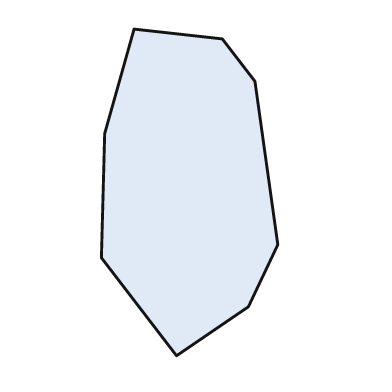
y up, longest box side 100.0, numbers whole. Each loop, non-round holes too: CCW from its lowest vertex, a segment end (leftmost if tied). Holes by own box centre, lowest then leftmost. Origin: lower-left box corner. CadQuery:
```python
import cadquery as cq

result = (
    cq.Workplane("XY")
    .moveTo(23.0, 0.0)
    .lineTo(45.0, 15.0)
    .lineTo(54.0, 34.0)
    .lineTo(47.0, 84.0)
    .lineTo(37.0, 97.0)
    .lineTo(10.0, 100.0)
    .lineTo(1.0, 68.0)
    .lineTo(0.0, 30.0)
    .close()
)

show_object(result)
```